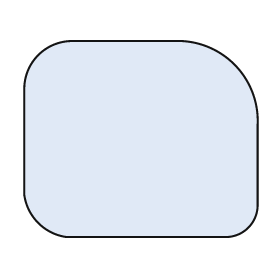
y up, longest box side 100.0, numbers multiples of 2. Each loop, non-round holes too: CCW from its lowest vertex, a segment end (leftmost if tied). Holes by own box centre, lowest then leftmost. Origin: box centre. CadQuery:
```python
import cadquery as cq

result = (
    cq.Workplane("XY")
    .moveTo(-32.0, -42.0)
    .lineTo(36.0, -42.0)
    .threePointArc((46.0, -38.0), (50.0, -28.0))
    .lineTo(50.0, 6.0)
    .threePointArc((40.0, 32.0), (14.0, 42.0))
    .lineTo(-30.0, 42.0)
    .threePointArc((-44.0, 36.0), (-50.0, 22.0))
    .lineTo(-50.0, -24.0)
    .threePointArc((-44.0, -36.0), (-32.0, -42.0))
    .close()
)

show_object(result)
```